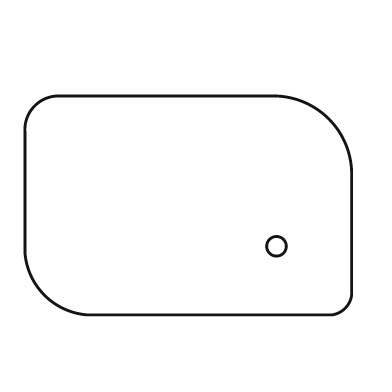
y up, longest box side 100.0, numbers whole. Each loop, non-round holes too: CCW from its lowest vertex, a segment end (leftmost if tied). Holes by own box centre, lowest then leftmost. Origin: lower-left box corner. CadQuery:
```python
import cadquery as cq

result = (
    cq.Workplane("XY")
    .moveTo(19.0, 0.0)
    .lineTo(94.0, 0.0)
    .threePointArc((98.0, 2.0), (100.0, 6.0))
    .lineTo(100.0, 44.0)
    .threePointArc((93.0, 60.0), (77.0, 67.0))
    .lineTo(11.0, 67.0)
    .threePointArc((3.0, 64.0), (0.0, 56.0))
    .lineTo(0.0, 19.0)
    .threePointArc((6.0, 6.0), (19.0, 0.0))
    .close()
    .moveTo(77.0, 21.0)
    .circle(3.0)
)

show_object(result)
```